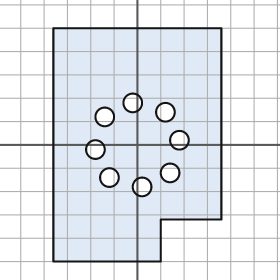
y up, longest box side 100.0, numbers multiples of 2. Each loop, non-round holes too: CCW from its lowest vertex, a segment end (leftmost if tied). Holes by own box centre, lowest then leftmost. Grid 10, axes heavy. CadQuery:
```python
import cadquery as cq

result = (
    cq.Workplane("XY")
    .moveTo(-36.0, -50.0)
    .lineTo(10.0, -50.0)
    .lineTo(10.0, -32.0)
    .lineTo(36.0, -32.0)
    .lineTo(36.0, 50.0)
    .lineTo(-36.0, 50.0)
    .close()
    .moveTo(2.0, -18.0)
    .circle(4.0)
    .moveTo(-12.0, -14.0)
    .circle(4.0)
    .moveTo(14.0, -12.0)
    .circle(4.0)
    .moveTo(-18.0, -2.0)
    .circle(4.0)
    .moveTo(18.0, 2.0)
    .circle(4.0)
    .moveTo(-14.0, 12.0)
    .circle(4.0)
    .moveTo(12.0, 14.0)
    .circle(4.0)
    .moveTo(-2.0, 18.0)
    .circle(4.0)
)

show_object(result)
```